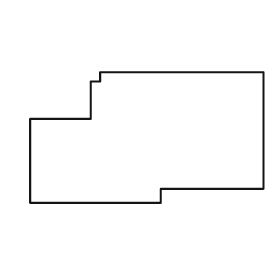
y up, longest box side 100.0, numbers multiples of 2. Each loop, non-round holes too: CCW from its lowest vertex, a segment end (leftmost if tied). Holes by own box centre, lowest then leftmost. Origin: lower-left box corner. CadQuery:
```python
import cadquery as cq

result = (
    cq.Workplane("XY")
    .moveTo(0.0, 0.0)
    .lineTo(56.0, 0.0)
    .lineTo(56.0, 6.0)
    .lineTo(100.0, 6.0)
    .lineTo(100.0, 56.0)
    .lineTo(30.0, 56.0)
    .lineTo(30.0, 52.0)
    .lineTo(26.0, 52.0)
    .lineTo(26.0, 36.0)
    .lineTo(0.0, 36.0)
    .close()
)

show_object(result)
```